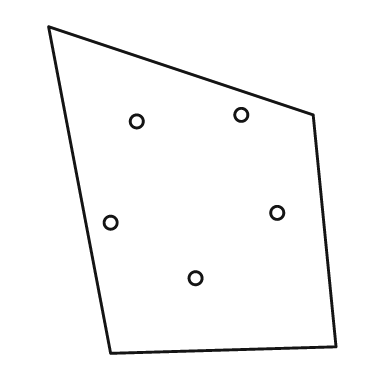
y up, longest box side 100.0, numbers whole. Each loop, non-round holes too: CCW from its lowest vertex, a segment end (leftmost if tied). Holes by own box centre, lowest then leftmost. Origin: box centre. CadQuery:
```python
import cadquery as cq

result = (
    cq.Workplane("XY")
    .moveTo(-25.0, -50.0)
    .lineTo(44.0, -48.0)
    .lineTo(37.0, 23.0)
    .lineTo(-44.0, 50.0)
    .close()
    .moveTo(1.0, -27.0)
    .circle(2.0)
    .moveTo(-25.0, -10.0)
    .circle(2.0)
    .moveTo(26.0, -7.0)
    .circle(2.0)
    .moveTo(-17.0, 21.0)
    .circle(2.0)
    .moveTo(15.0, 23.0)
    .circle(2.0)
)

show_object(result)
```